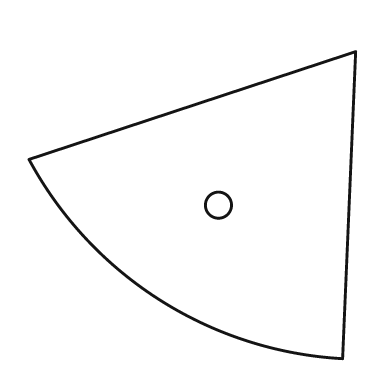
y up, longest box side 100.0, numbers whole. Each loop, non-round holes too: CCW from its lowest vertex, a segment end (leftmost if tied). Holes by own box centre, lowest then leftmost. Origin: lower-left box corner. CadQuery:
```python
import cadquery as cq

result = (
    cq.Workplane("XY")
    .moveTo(96.0, 0.0)
    .lineTo(100.0, 94.0)
    .lineTo(0.0, 61.0)
    .threePointArc((40.0, 18.0), (96.0, 0.0))
    .close()
    .moveTo(58.0, 47.0)
    .circle(4.0)
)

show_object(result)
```